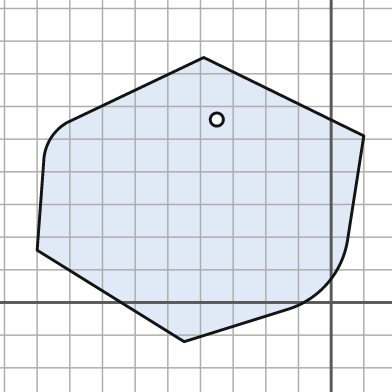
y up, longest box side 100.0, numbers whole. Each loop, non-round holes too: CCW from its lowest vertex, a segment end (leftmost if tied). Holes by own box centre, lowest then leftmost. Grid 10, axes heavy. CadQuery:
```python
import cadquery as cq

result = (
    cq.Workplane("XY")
    .moveTo(-45.0, -12.0)
    .lineTo(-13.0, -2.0)
    .threePointArc((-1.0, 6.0), (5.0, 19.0))
    .lineTo(10.0, 51.0)
    .lineTo(-39.0, 75.0)
    .lineTo(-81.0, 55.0)
    .threePointArc((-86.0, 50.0), (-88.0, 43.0))
    .lineTo(-90.0, 16.0)
    .close()
    .moveTo(-35.0, 56.0)
    .circle(2.0)
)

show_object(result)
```